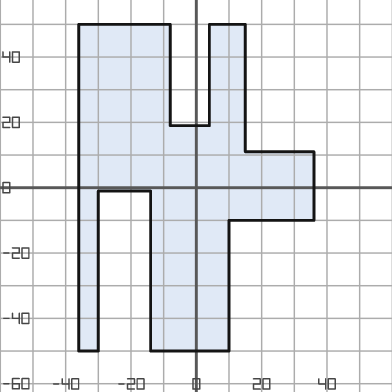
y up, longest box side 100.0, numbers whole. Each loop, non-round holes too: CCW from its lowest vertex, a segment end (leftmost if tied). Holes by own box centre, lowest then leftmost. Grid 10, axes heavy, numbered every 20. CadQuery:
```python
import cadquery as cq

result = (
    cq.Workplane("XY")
    .moveTo(-36.0, -50.0)
    .lineTo(-30.0, -50.0)
    .lineTo(-30.0, -1.0)
    .lineTo(-14.0, -1.0)
    .lineTo(-14.0, -50.0)
    .lineTo(10.0, -50.0)
    .lineTo(10.0, -10.0)
    .lineTo(36.0, -10.0)
    .lineTo(36.0, 11.0)
    .lineTo(15.0, 11.0)
    .lineTo(15.0, 50.0)
    .lineTo(4.0, 50.0)
    .lineTo(4.0, 19.0)
    .lineTo(-8.0, 19.0)
    .lineTo(-8.0, 50.0)
    .lineTo(-36.0, 50.0)
    .close()
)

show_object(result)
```